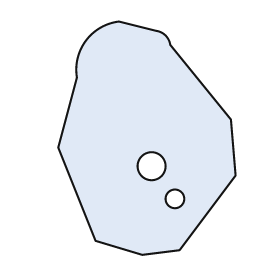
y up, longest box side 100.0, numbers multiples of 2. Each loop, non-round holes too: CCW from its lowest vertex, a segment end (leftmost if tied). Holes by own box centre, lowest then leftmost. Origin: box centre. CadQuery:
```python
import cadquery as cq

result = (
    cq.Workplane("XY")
    .moveTo(-2.0, -50.0)
    .lineTo(14.0, -48.0)
    .lineTo(38.0, -16.0)
    .lineTo(36.0, 8.0)
    .lineTo(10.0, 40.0)
    .threePointArc((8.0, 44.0), (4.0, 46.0))
    .lineTo(-12.0, 50.0)
    .threePointArc((-26.0, 42.0), (-30.0, 26.0))
    .lineTo(-38.0, -4.0)
    .lineTo(-22.0, -44.0)
    .close()
    .moveTo(12.0, -26.0)
    .circle(4.0)
    .moveTo(2.0, -12.0)
    .circle(6.0)
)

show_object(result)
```